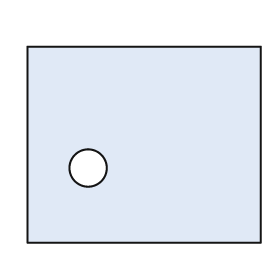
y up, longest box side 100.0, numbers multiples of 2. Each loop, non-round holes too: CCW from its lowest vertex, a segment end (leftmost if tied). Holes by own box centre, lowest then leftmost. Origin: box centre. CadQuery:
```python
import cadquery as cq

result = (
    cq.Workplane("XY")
    .moveTo(-50.0, -42.0)
    .lineTo(50.0, -42.0)
    .lineTo(50.0, 42.0)
    .lineTo(-50.0, 42.0)
    .close()
    .moveTo(-24.0, -10.0)
    .circle(8.0)
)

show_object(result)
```